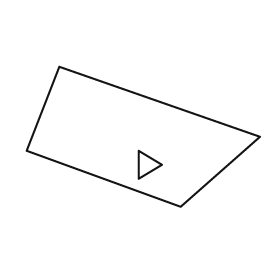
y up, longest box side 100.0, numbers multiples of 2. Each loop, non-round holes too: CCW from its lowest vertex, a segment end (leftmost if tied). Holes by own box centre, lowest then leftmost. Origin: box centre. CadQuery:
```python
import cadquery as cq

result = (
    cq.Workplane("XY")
    .moveTo(16.0, -30.0)
    .lineTo(50.0, 0.0)
    .lineTo(-36.0, 30.0)
    .lineTo(-50.0, -6.0)
    .close()
    .moveTo(-2.0, -18.0)
    .lineTo(8.0, -12.0)
    .lineTo(-2.0, -6.0)
    .close()
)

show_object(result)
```